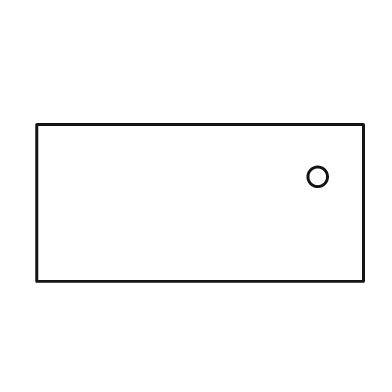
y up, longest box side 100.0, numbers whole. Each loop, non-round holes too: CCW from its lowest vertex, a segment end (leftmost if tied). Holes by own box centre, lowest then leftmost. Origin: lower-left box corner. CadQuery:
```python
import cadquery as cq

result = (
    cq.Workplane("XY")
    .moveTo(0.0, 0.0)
    .lineTo(100.0, 0.0)
    .lineTo(100.0, 48.0)
    .lineTo(0.0, 48.0)
    .close()
    .moveTo(86.0, 32.0)
    .circle(3.0)
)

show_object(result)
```